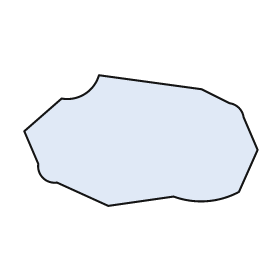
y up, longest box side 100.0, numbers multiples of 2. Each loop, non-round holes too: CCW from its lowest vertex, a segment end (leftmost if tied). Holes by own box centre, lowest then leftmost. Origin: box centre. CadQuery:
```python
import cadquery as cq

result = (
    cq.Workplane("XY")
    .moveTo(-14.0, -28.0)
    .lineTo(14.0, -24.0)
    .threePointArc((28.0, -26.0), (42.0, -22.0))
    .lineTo(50.0, -4.0)
    .lineTo(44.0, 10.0)
    .threePointArc((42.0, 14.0), (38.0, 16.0))
    .lineTo(26.0, 22.0)
    .lineTo(-18.0, 28.0)
    .threePointArc((-24.0, 20.0), (-34.0, 18.0))
    .lineTo(-50.0, 4.0)
    .lineTo(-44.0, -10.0)
    .threePointArc((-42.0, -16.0), (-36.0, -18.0))
    .close()
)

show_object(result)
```